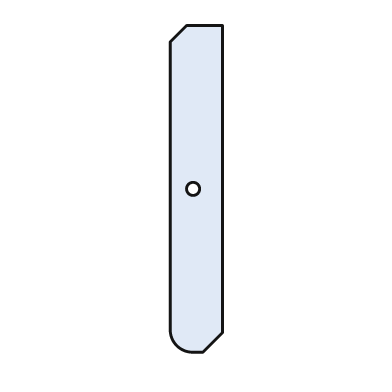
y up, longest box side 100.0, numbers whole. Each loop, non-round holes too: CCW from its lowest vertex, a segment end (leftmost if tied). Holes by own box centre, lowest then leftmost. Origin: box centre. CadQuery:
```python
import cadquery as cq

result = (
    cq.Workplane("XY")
    .moveTo(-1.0, -50.0)
    .lineTo(2.0, -50.0)
    .lineTo(8.0, -44.0)
    .lineTo(8.0, 50.0)
    .lineTo(-3.0, 50.0)
    .lineTo(-8.0, 45.0)
    .lineTo(-8.0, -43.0)
    .threePointArc((-6.0, -48.0), (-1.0, -50.0))
    .close()
    .moveTo(-1.0, 0.0)
    .circle(2.0)
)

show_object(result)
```